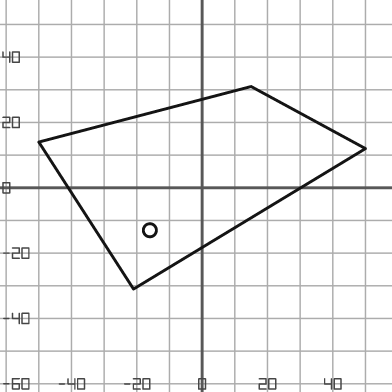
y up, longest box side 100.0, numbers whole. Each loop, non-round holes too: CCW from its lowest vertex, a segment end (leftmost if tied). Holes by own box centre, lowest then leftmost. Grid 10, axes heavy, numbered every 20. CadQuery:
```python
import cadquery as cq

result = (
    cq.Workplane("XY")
    .moveTo(-21.0, -31.0)
    .lineTo(50.0, 12.0)
    .lineTo(15.0, 31.0)
    .lineTo(-50.0, 14.0)
    .close()
    .moveTo(-16.0, -13.0)
    .circle(2.0)
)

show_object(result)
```